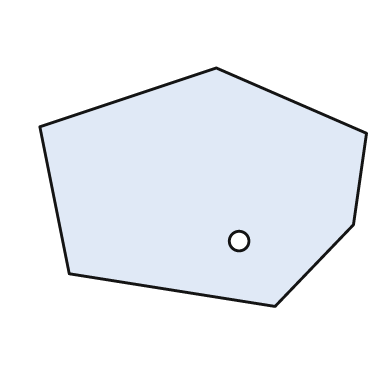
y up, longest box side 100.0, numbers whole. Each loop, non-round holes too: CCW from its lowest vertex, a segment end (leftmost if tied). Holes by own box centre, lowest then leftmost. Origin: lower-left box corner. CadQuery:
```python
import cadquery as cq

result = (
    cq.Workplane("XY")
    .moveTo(72.0, 0.0)
    .lineTo(96.0, 25.0)
    .lineTo(100.0, 53.0)
    .lineTo(54.0, 73.0)
    .lineTo(0.0, 55.0)
    .lineTo(9.0, 10.0)
    .close()
    .moveTo(61.0, 20.0)
    .circle(3.0)
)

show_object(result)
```